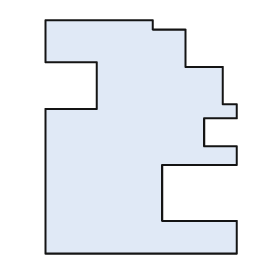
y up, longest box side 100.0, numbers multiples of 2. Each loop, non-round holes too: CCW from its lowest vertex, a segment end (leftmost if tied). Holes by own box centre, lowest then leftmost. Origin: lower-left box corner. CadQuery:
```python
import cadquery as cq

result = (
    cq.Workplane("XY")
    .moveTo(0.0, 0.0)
    .lineTo(82.0, 0.0)
    .lineTo(82.0, 14.0)
    .lineTo(50.0, 14.0)
    .lineTo(50.0, 38.0)
    .lineTo(82.0, 38.0)
    .lineTo(82.0, 46.0)
    .lineTo(68.0, 46.0)
    .lineTo(68.0, 58.0)
    .lineTo(82.0, 58.0)
    .lineTo(82.0, 64.0)
    .lineTo(76.0, 64.0)
    .lineTo(76.0, 80.0)
    .lineTo(60.0, 80.0)
    .lineTo(60.0, 96.0)
    .lineTo(46.0, 96.0)
    .lineTo(46.0, 100.0)
    .lineTo(0.0, 100.0)
    .lineTo(0.0, 82.0)
    .lineTo(22.0, 82.0)
    .lineTo(22.0, 62.0)
    .lineTo(0.0, 62.0)
    .close()
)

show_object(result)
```